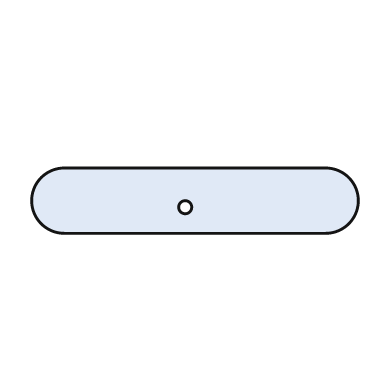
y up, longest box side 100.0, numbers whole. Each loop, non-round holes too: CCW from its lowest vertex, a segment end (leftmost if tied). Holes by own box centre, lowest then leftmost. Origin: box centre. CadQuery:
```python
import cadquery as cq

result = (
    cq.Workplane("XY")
    .moveTo(-40.0, -10.0)
    .lineTo(40.0, -10.0)
    .threePointArc((50.0, 0.0), (40.0, 10.0))
    .lineTo(-40.0, 10.0)
    .threePointArc((-50.0, 0.0), (-40.0, -10.0))
    .close()
    .moveTo(-3.0, -2.0)
    .circle(2.0)
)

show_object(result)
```